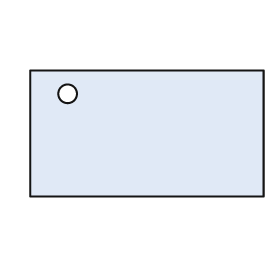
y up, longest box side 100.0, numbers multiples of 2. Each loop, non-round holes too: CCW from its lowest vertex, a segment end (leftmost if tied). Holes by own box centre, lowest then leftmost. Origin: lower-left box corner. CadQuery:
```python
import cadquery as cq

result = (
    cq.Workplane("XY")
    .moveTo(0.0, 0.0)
    .lineTo(100.0, 0.0)
    .lineTo(100.0, 54.0)
    .lineTo(0.0, 54.0)
    .close()
    .moveTo(16.0, 44.0)
    .circle(4.0)
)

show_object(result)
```